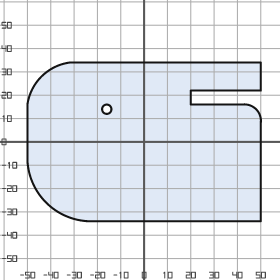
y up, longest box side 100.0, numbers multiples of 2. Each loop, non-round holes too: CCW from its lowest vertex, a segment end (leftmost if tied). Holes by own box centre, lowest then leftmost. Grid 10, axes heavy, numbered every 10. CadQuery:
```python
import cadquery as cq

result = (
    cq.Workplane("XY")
    .moveTo(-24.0, -34.0)
    .lineTo(50.0, -34.0)
    .lineTo(50.0, 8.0)
    .threePointArc((48.0, 14.0), (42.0, 16.0))
    .lineTo(20.0, 16.0)
    .lineTo(20.0, 22.0)
    .lineTo(50.0, 22.0)
    .lineTo(50.0, 34.0)
    .lineTo(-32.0, 34.0)
    .threePointArc((-44.0, 28.0), (-50.0, 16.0))
    .lineTo(-50.0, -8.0)
    .threePointArc((-42.0, -26.0), (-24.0, -34.0))
    .close()
    .moveTo(-16.0, 14.0)
    .circle(2.0)
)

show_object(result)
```